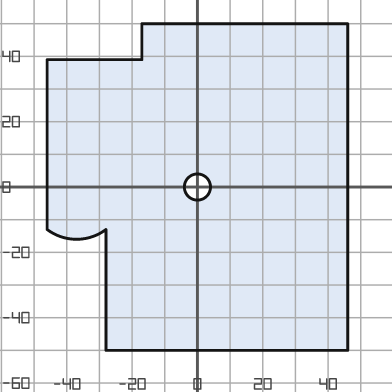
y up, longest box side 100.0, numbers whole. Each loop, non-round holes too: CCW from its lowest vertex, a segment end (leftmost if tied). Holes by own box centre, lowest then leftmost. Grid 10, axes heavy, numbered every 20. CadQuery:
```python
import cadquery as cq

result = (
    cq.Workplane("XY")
    .moveTo(-28.0, -50.0)
    .lineTo(46.0, -50.0)
    .lineTo(46.0, 50.0)
    .lineTo(-17.0, 50.0)
    .lineTo(-17.0, 39.0)
    .lineTo(-46.0, 39.0)
    .lineTo(-46.0, -13.0)
    .threePointArc((-37.0, -16.0), (-28.0, -13.0))
    .close()
    .moveTo(0.0, 0.0)
    .circle(4.0)
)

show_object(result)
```